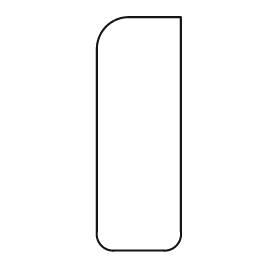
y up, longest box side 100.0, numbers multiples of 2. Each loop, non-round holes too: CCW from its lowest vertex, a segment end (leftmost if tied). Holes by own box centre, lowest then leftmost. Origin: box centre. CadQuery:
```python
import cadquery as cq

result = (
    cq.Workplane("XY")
    .moveTo(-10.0, -50.0)
    .lineTo(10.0, -50.0)
    .threePointArc((16.0, -48.0), (18.0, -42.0))
    .lineTo(18.0, 50.0)
    .lineTo(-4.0, 50.0)
    .threePointArc((-14.0, 46.0), (-18.0, 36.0))
    .lineTo(-18.0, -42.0)
    .threePointArc((-16.0, -48.0), (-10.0, -50.0))
    .close()
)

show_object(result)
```